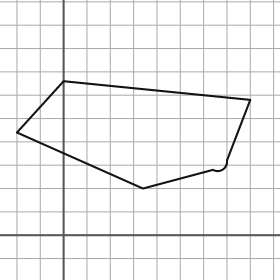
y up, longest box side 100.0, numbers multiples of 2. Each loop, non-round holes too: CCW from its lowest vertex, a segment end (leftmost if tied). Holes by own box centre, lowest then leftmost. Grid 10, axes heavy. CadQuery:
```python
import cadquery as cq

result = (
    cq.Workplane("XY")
    .moveTo(34.0, 20.0)
    .lineTo(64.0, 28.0)
    .threePointArc((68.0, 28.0), (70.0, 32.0))
    .lineTo(80.0, 58.0)
    .lineTo(0.0, 66.0)
    .lineTo(-20.0, 44.0)
    .close()
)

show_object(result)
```